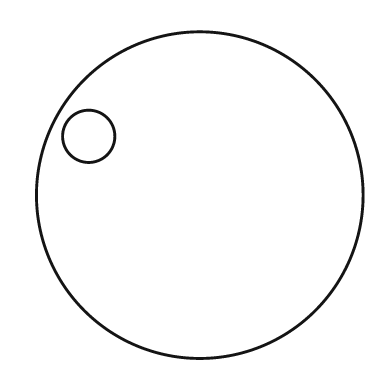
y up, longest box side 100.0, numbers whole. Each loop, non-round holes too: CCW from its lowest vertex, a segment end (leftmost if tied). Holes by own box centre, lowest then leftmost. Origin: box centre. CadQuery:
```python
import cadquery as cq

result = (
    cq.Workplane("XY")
    .moveTo(0.0, 0.0)
    .circle(50.0)
    .moveTo(-34.0, 18.0)
    .circle(8.0)
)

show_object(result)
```